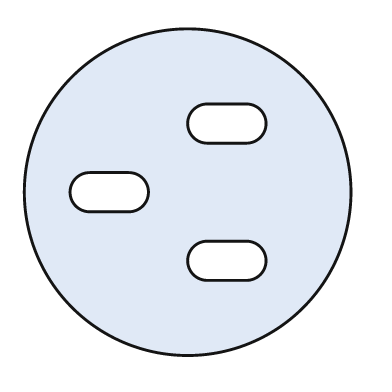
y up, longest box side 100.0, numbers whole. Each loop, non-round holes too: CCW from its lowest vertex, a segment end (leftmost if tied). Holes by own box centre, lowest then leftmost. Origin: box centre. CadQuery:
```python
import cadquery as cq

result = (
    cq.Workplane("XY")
    .moveTo(0.0, 0.0)
    .circle(50.0)
    .moveTo(6.0, -27.0)
    .lineTo(18.0, -27.0)
    .threePointArc((24.0, -21.0), (18.0, -15.0))
    .lineTo(6.0, -15.0)
    .threePointArc((0.0, -21.0), (6.0, -27.0))
    .close()
    .moveTo(-30.0, -6.0)
    .lineTo(-18.0, -6.0)
    .threePointArc((-12.0, 0.0), (-18.0, 6.0))
    .lineTo(-30.0, 6.0)
    .threePointArc((-36.0, 0.0), (-30.0, -6.0))
    .close()
    .moveTo(6.0, 15.0)
    .lineTo(18.0, 15.0)
    .threePointArc((24.0, 21.0), (18.0, 27.0))
    .lineTo(6.0, 27.0)
    .threePointArc((0.0, 21.0), (6.0, 15.0))
    .close()
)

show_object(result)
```